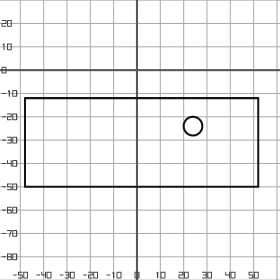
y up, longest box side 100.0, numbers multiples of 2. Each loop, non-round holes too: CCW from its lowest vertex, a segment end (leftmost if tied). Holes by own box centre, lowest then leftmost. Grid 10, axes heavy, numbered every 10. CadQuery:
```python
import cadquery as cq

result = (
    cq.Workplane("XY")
    .moveTo(-48.0, -50.0)
    .lineTo(52.0, -50.0)
    .lineTo(52.0, -12.0)
    .lineTo(-48.0, -12.0)
    .close()
    .moveTo(24.0, -24.0)
    .circle(4.0)
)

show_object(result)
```